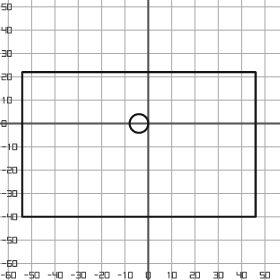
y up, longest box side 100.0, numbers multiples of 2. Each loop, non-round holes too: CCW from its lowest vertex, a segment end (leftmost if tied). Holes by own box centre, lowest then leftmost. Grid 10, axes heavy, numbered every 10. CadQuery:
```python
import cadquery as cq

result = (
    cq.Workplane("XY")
    .moveTo(-54.0, -40.0)
    .lineTo(46.0, -40.0)
    .lineTo(46.0, 22.0)
    .lineTo(-54.0, 22.0)
    .close()
    .moveTo(-4.0, 0.0)
    .circle(4.0)
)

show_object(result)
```